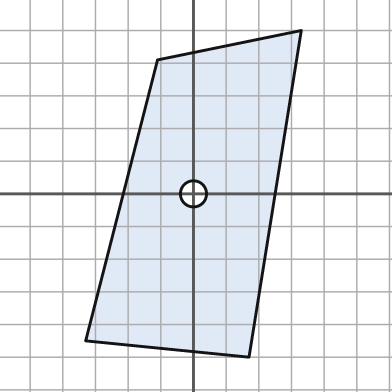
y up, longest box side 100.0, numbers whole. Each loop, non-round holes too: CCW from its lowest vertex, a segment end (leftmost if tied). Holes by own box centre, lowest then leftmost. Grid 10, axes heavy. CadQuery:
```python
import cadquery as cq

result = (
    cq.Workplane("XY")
    .moveTo(17.0, -50.0)
    .lineTo(33.0, 50.0)
    .lineTo(-11.0, 41.0)
    .lineTo(-33.0, -45.0)
    .close()
    .moveTo(0.0, 0.0)
    .circle(4.0)
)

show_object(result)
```